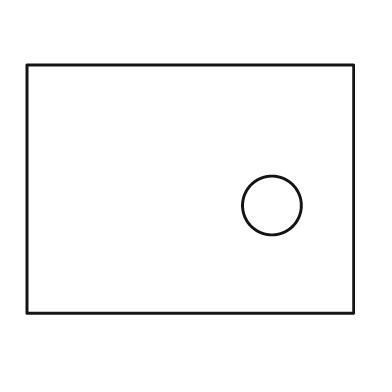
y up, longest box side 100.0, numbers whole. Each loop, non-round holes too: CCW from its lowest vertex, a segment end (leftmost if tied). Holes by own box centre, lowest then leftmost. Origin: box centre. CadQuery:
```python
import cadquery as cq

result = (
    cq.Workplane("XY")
    .moveTo(-50.0, -38.0)
    .lineTo(50.0, -38.0)
    .lineTo(50.0, 38.0)
    .lineTo(-50.0, 38.0)
    .close()
    .moveTo(25.0, -5.0)
    .circle(9.0)
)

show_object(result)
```